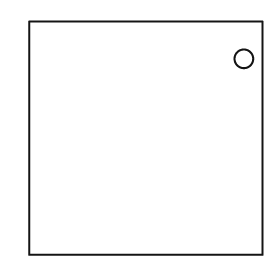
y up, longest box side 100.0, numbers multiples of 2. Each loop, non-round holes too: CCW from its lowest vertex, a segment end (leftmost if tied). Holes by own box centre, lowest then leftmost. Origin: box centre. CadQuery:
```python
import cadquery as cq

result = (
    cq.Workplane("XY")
    .moveTo(-50.0, -50.0)
    .lineTo(50.0, -50.0)
    .lineTo(50.0, 50.0)
    .lineTo(-50.0, 50.0)
    .close()
    .moveTo(42.0, 34.0)
    .circle(4.0)
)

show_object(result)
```